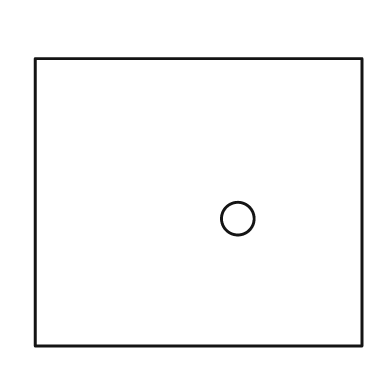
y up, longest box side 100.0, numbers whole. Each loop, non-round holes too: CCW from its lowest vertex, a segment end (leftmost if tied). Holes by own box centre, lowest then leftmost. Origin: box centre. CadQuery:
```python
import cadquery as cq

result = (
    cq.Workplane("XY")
    .moveTo(-50.0, -44.0)
    .lineTo(50.0, -44.0)
    .lineTo(50.0, 44.0)
    .lineTo(-50.0, 44.0)
    .close()
    .moveTo(12.0, -5.0)
    .circle(5.0)
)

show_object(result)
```